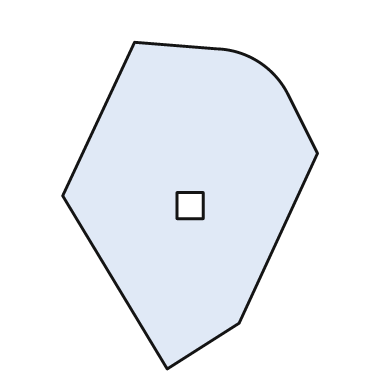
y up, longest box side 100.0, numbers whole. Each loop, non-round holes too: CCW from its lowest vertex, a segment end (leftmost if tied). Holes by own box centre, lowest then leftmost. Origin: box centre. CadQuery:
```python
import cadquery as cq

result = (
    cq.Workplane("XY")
    .moveTo(-7.0, -50.0)
    .lineTo(15.0, -36.0)
    .lineTo(39.0, 16.0)
    .lineTo(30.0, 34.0)
    .threePointArc((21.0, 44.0), (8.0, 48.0))
    .lineTo(-17.0, 50.0)
    .lineTo(-39.0, 3.0)
    .close()
    .moveTo(-4.0, -4.0)
    .lineTo(4.0, -4.0)
    .lineTo(4.0, 4.0)
    .lineTo(-4.0, 4.0)
    .close()
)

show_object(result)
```